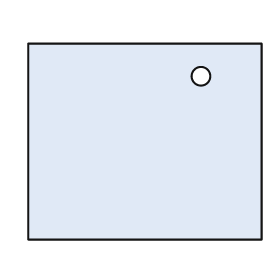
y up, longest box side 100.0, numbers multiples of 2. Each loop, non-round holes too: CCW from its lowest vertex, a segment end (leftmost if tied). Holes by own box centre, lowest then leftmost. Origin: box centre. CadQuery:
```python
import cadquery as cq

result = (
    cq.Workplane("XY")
    .moveTo(-50.0, -42.0)
    .lineTo(50.0, -42.0)
    .lineTo(50.0, 42.0)
    .lineTo(-50.0, 42.0)
    .close()
    .moveTo(24.0, 28.0)
    .circle(4.0)
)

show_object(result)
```